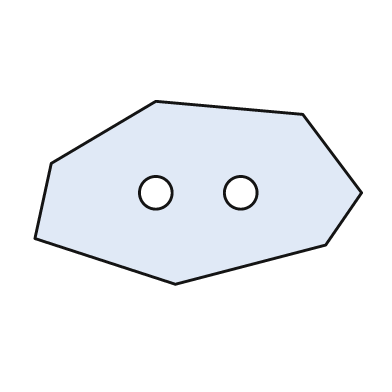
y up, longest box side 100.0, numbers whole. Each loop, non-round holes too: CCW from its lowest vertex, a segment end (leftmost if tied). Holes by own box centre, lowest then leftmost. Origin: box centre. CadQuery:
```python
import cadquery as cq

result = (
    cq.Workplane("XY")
    .moveTo(-7.0, -28.0)
    .lineTo(39.0, -16.0)
    .lineTo(50.0, 0.0)
    .lineTo(32.0, 24.0)
    .lineTo(-13.0, 28.0)
    .lineTo(-45.0, 9.0)
    .lineTo(-50.0, -14.0)
    .close()
    .moveTo(-13.0, 0.0)
    .circle(5.0)
    .moveTo(13.0, 0.0)
    .circle(5.0)
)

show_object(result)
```